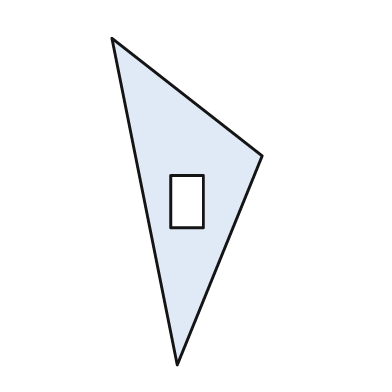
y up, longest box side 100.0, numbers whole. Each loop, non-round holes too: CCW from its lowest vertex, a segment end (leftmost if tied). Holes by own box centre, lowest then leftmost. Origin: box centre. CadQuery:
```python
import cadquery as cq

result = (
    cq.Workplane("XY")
    .moveTo(-3.0, -50.0)
    .lineTo(23.0, 14.0)
    .lineTo(-23.0, 50.0)
    .close()
    .moveTo(-5.0, -8.0)
    .lineTo(5.0, -8.0)
    .lineTo(5.0, 8.0)
    .lineTo(-5.0, 8.0)
    .close()
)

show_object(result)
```